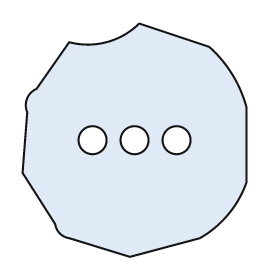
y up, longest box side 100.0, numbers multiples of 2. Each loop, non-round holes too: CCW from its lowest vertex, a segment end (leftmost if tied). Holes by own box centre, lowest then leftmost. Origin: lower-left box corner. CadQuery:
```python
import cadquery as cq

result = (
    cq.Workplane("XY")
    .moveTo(46.0, 0.0)
    .lineTo(76.0, 8.0)
    .threePointArc((88.0, 18.0), (96.0, 32.0))
    .lineTo(96.0, 64.0)
    .threePointArc((90.0, 78.0), (80.0, 90.0))
    .lineTo(50.0, 100.0)
    .threePointArc((36.0, 92.0), (20.0, 92.0))
    .lineTo(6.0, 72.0)
    .threePointArc((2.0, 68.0), (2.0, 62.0))
    .lineTo(0.0, 36.0)
    .lineTo(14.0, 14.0)
    .threePointArc((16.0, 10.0), (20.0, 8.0))
    .close()
    .moveTo(30.0, 50.0)
    .circle(6.0)
    .moveTo(48.0, 50.0)
    .circle(6.0)
    .moveTo(66.0, 50.0)
    .circle(6.0)
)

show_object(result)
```